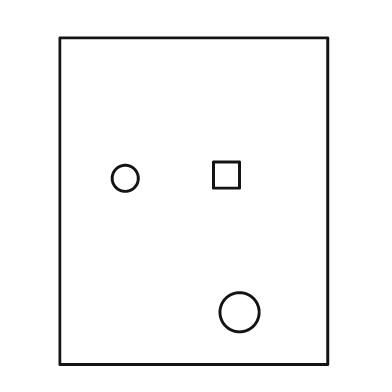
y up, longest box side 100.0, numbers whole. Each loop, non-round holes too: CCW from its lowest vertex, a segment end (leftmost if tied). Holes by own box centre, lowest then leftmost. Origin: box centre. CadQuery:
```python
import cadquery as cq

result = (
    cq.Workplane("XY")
    .moveTo(-41.0, -50.0)
    .lineTo(41.0, -50.0)
    .lineTo(41.0, 50.0)
    .lineTo(-41.0, 50.0)
    .close()
    .moveTo(14.0, -34.0)
    .circle(6.0)
    .moveTo(-21.0, 7.0)
    .circle(4.0)
    .moveTo(6.0, 4.0)
    .lineTo(14.0, 4.0)
    .lineTo(14.0, 12.0)
    .lineTo(6.0, 12.0)
    .close()
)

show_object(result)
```